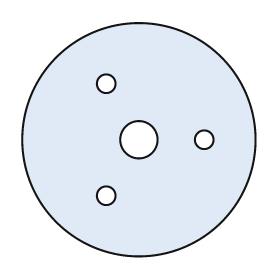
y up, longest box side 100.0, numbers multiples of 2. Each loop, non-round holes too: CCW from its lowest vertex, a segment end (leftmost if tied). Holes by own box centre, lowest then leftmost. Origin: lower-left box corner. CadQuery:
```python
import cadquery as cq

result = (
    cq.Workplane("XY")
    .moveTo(50.0, 50.0)
    .circle(50.0)
    .moveTo(36.0, 26.0)
    .circle(4.0)
    .moveTo(50.0, 50.0)
    .circle(8.0)
    .moveTo(78.0, 50.0)
    .circle(4.0)
    .moveTo(36.0, 74.0)
    .circle(4.0)
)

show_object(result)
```